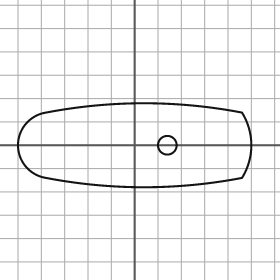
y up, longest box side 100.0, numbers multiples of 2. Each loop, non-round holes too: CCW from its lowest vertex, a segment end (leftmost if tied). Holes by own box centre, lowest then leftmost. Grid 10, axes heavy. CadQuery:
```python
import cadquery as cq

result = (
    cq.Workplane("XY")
    .moveTo(-38.0, -14.0)
    .threePointArc((4.0, -18.0), (46.0, -14.0))
    .threePointArc((50.0, 0.0), (46.0, 14.0))
    .threePointArc((4.0, 18.0), (-38.0, 14.0))
    .threePointArc((-50.0, 0.0), (-38.0, -14.0))
    .close()
    .moveTo(14.0, 0.0)
    .circle(4.0)
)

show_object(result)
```